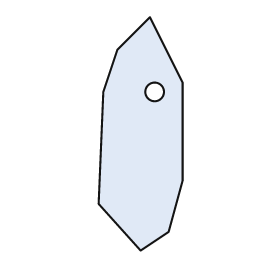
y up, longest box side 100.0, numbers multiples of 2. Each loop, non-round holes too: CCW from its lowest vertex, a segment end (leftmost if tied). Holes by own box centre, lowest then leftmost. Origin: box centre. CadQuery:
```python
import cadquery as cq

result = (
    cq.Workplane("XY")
    .moveTo(0.0, -50.0)
    .lineTo(12.0, -42.0)
    .lineTo(18.0, -20.0)
    .lineTo(18.0, 22.0)
    .lineTo(4.0, 50.0)
    .lineTo(-10.0, 36.0)
    .lineTo(-16.0, 18.0)
    .lineTo(-18.0, -30.0)
    .close()
    .moveTo(6.0, 18.0)
    .circle(4.0)
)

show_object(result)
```